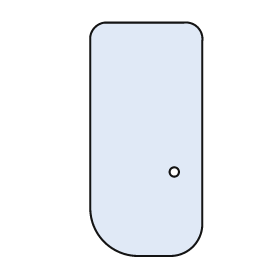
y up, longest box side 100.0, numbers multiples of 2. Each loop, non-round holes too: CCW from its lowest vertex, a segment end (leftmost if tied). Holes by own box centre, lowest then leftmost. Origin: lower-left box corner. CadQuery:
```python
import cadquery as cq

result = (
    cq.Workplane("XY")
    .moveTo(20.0, 0.0)
    .lineTo(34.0, 0.0)
    .threePointArc((44.0, 4.0), (48.0, 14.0))
    .lineTo(48.0, 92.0)
    .threePointArc((46.0, 98.0), (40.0, 100.0))
    .lineTo(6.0, 100.0)
    .threePointArc((2.0, 98.0), (0.0, 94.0))
    .lineTo(0.0, 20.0)
    .threePointArc((6.0, 6.0), (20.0, 0.0))
    .close()
    .moveTo(36.0, 36.0)
    .circle(2.0)
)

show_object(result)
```